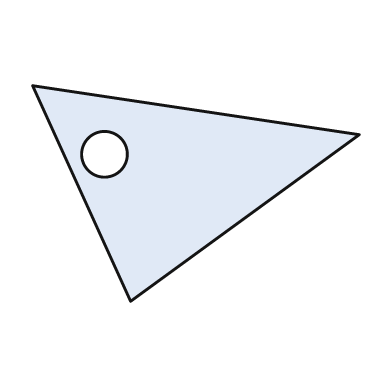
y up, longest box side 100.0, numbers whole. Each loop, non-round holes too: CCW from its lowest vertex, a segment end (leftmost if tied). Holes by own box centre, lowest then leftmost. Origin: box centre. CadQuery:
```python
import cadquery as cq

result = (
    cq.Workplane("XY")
    .moveTo(-20.0, -33.0)
    .lineTo(50.0, 18.0)
    .lineTo(-50.0, 33.0)
    .close()
    .moveTo(-28.0, 12.0)
    .circle(7.0)
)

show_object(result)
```